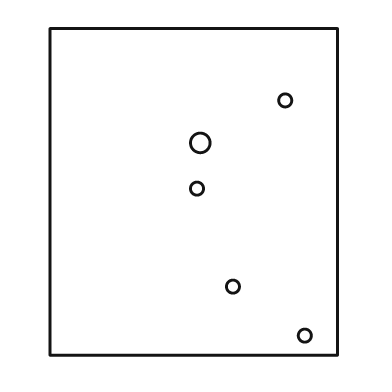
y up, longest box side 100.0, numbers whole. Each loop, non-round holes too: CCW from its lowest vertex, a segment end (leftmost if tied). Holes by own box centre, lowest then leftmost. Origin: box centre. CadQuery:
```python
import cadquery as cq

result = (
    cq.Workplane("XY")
    .moveTo(-44.0, -50.0)
    .lineTo(44.0, -50.0)
    .lineTo(44.0, 50.0)
    .lineTo(-44.0, 50.0)
    .close()
    .moveTo(34.0, -44.0)
    .circle(2.0)
    .moveTo(12.0, -29.0)
    .circle(2.0)
    .moveTo(1.0, 1.0)
    .circle(2.0)
    .moveTo(2.0, 15.0)
    .circle(3.0)
    .moveTo(28.0, 28.0)
    .circle(2.0)
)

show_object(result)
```